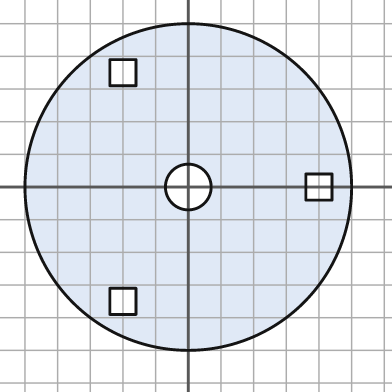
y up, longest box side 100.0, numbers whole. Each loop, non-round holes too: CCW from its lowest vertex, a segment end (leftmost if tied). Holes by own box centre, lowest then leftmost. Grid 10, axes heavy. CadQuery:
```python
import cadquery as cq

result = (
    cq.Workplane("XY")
    .moveTo(0.0, 0.0)
    .circle(50.0)
    .moveTo(-24.0, -39.0)
    .lineTo(-16.0, -39.0)
    .lineTo(-16.0, -31.0)
    .lineTo(-24.0, -31.0)
    .close()
    .moveTo(0.0, 0.0)
    .circle(7.0)
    .moveTo(36.0, -4.0)
    .lineTo(44.0, -4.0)
    .lineTo(44.0, 4.0)
    .lineTo(36.0, 4.0)
    .close()
    .moveTo(-24.0, 31.0)
    .lineTo(-16.0, 31.0)
    .lineTo(-16.0, 39.0)
    .lineTo(-24.0, 39.0)
    .close()
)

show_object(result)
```